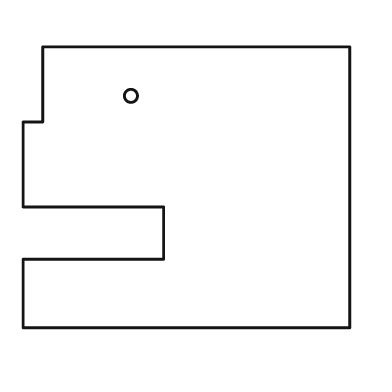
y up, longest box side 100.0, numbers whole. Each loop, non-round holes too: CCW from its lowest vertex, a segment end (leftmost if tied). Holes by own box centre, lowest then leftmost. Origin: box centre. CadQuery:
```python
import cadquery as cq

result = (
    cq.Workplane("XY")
    .moveTo(-50.0, -43.0)
    .lineTo(50.0, -43.0)
    .lineTo(50.0, 43.0)
    .lineTo(-44.0, 43.0)
    .lineTo(-44.0, 20.0)
    .lineTo(-50.0, 20.0)
    .lineTo(-50.0, -6.0)
    .lineTo(-7.0, -6.0)
    .lineTo(-7.0, -22.0)
    .lineTo(-50.0, -22.0)
    .close()
    .moveTo(-17.0, 28.0)
    .circle(2.0)
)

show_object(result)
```